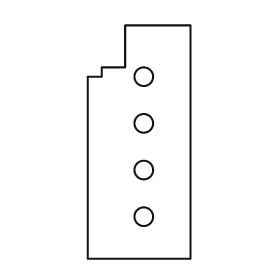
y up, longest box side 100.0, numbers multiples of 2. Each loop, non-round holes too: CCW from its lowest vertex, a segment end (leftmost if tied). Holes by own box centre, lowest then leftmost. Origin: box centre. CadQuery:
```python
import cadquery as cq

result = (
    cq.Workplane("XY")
    .moveTo(-22.0, -50.0)
    .lineTo(22.0, -50.0)
    .lineTo(22.0, 50.0)
    .lineTo(-6.0, 50.0)
    .lineTo(-6.0, 32.0)
    .lineTo(-16.0, 32.0)
    .lineTo(-16.0, 28.0)
    .lineTo(-22.0, 28.0)
    .close()
    .moveTo(2.0, -32.0)
    .circle(4.0)
    .moveTo(2.0, -12.0)
    .circle(4.0)
    .moveTo(2.0, 8.0)
    .circle(4.0)
    .moveTo(2.0, 28.0)
    .circle(4.0)
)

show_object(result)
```